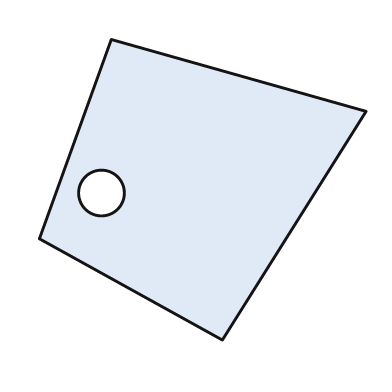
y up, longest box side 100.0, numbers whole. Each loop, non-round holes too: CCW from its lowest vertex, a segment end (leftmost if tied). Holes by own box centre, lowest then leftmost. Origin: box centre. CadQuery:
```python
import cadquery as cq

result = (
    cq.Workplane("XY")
    .moveTo(6.0, -46.0)
    .lineTo(50.0, 24.0)
    .lineTo(-28.0, 46.0)
    .lineTo(-50.0, -15.0)
    .close()
    .moveTo(-31.0, -1.0)
    .circle(7.0)
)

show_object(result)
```